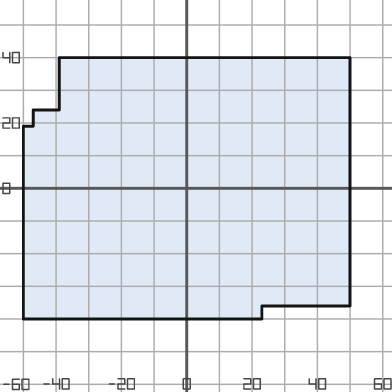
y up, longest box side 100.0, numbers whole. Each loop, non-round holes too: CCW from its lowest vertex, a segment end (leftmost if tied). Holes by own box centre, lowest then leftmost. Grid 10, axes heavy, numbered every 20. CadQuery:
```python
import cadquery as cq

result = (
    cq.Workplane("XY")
    .moveTo(-50.0, -40.0)
    .lineTo(23.0, -40.0)
    .lineTo(23.0, -36.0)
    .lineTo(50.0, -36.0)
    .lineTo(50.0, 40.0)
    .lineTo(-39.0, 40.0)
    .lineTo(-39.0, 24.0)
    .lineTo(-47.0, 24.0)
    .lineTo(-47.0, 19.0)
    .lineTo(-50.0, 19.0)
    .close()
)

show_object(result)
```